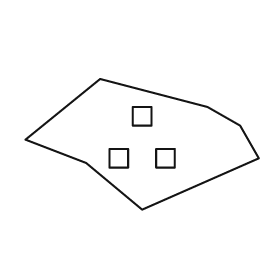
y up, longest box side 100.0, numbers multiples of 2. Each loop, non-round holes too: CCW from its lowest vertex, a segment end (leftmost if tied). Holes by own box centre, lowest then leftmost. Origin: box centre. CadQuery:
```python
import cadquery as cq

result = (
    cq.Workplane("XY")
    .moveTo(0.0, -28.0)
    .lineTo(50.0, -6.0)
    .lineTo(42.0, 8.0)
    .lineTo(28.0, 16.0)
    .lineTo(-18.0, 28.0)
    .lineTo(-50.0, 2.0)
    .lineTo(-24.0, -8.0)
    .close()
    .moveTo(-14.0, -10.0)
    .lineTo(-6.0, -10.0)
    .lineTo(-6.0, -2.0)
    .lineTo(-14.0, -2.0)
    .close()
    .moveTo(6.0, -10.0)
    .lineTo(14.0, -10.0)
    .lineTo(14.0, -2.0)
    .lineTo(6.0, -2.0)
    .close()
    .moveTo(-4.0, 8.0)
    .lineTo(4.0, 8.0)
    .lineTo(4.0, 16.0)
    .lineTo(-4.0, 16.0)
    .close()
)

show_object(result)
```